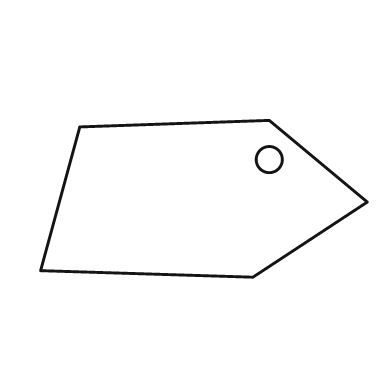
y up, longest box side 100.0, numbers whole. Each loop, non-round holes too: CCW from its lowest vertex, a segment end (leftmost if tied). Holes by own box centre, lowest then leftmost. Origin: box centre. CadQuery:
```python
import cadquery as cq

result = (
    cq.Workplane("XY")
    .moveTo(15.0, -24.0)
    .lineTo(50.0, -1.0)
    .lineTo(20.0, 24.0)
    .lineTo(-38.0, 22.0)
    .lineTo(-50.0, -22.0)
    .close()
    .moveTo(20.0, 12.0)
    .circle(4.0)
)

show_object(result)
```